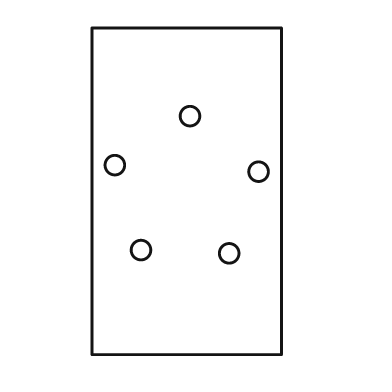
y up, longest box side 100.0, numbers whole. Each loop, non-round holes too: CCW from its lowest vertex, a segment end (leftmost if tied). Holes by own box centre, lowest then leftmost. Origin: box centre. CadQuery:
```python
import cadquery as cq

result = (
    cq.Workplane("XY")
    .moveTo(-29.0, -50.0)
    .lineTo(29.0, -50.0)
    .lineTo(29.0, 50.0)
    .lineTo(-29.0, 50.0)
    .close()
    .moveTo(13.0, -19.0)
    .circle(3.0)
    .moveTo(-14.0, -18.0)
    .circle(3.0)
    .moveTo(22.0, 6.0)
    .circle(3.0)
    .moveTo(-22.0, 8.0)
    .circle(3.0)
    .moveTo(1.0, 23.0)
    .circle(3.0)
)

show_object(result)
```